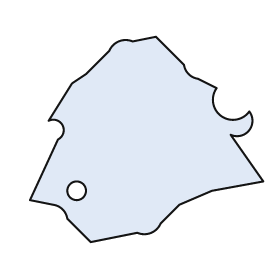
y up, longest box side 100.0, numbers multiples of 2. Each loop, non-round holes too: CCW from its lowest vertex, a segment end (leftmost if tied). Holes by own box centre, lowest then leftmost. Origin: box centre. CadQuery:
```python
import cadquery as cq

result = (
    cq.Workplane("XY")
    .moveTo(-24.0, -44.0)
    .lineTo(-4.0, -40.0)
    .threePointArc((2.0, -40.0), (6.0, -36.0))
    .lineTo(14.0, -28.0)
    .lineTo(28.0, -22.0)
    .lineTo(50.0, -18.0)
    .lineTo(36.0, 2.0)
    .threePointArc((44.0, 4.0), (44.0, 12.0))
    .threePointArc((32.0, 10.0), (30.0, 22.0))
    .lineTo(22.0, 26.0)
    .threePointArc((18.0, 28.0), (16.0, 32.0))
    .lineTo(4.0, 44.0)
    .lineTo(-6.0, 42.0)
    .threePointArc((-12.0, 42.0), (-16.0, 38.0))
    .lineTo(-26.0, 28.0)
    .lineTo(-32.0, 24.0)
    .lineTo(-42.0, 8.0)
    .threePointArc((-36.0, 6.0), (-38.0, 0.0))
    .lineTo(-50.0, -26.0)
    .lineTo(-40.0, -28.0)
    .threePointArc((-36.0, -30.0), (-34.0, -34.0))
    .close()
    .moveTo(-30.0, -22.0)
    .circle(4.0)
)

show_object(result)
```